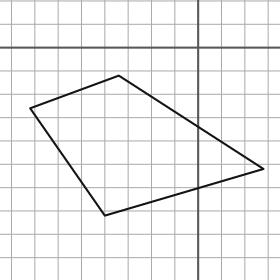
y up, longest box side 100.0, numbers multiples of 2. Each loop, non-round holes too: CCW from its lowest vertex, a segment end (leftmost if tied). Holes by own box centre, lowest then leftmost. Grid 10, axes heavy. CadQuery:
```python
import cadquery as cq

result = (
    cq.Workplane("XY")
    .moveTo(-40.0, -72.0)
    .lineTo(28.0, -52.0)
    .lineTo(-34.0, -12.0)
    .lineTo(-72.0, -26.0)
    .close()
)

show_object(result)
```